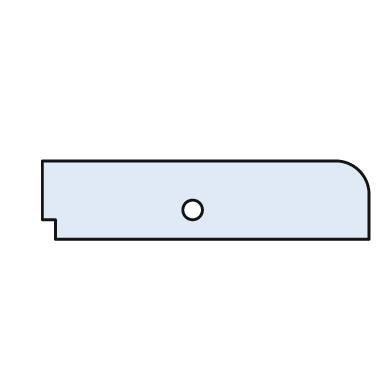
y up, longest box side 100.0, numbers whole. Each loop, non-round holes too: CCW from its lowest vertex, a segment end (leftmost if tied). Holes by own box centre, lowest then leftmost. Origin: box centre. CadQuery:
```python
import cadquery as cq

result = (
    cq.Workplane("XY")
    .moveTo(-46.0, -12.0)
    .lineTo(50.0, -12.0)
    .lineTo(50.0, 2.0)
    .threePointArc((47.0, 9.0), (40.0, 12.0))
    .lineTo(-50.0, 12.0)
    .lineTo(-50.0, -6.0)
    .lineTo(-46.0, -6.0)
    .close()
    .moveTo(-4.0, -3.0)
    .circle(3.0)
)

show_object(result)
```